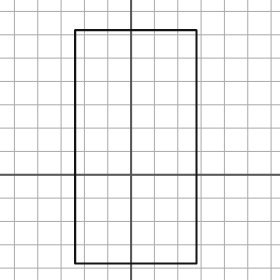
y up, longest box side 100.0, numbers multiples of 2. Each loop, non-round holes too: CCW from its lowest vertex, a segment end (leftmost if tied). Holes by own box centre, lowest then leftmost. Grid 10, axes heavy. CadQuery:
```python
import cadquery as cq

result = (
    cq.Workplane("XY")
    .moveTo(-24.0, -38.0)
    .lineTo(28.0, -38.0)
    .lineTo(28.0, 62.0)
    .lineTo(-24.0, 62.0)
    .close()
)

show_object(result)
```